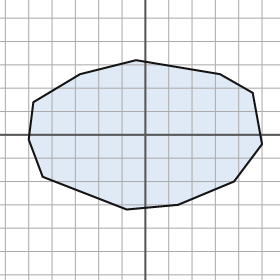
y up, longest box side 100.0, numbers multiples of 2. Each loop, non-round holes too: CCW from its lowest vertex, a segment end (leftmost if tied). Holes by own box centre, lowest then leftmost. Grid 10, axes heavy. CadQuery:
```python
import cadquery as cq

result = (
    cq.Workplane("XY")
    .moveTo(-8.0, -32.0)
    .lineTo(14.0, -30.0)
    .lineTo(38.0, -20.0)
    .lineTo(50.0, -4.0)
    .lineTo(46.0, 18.0)
    .lineTo(32.0, 26.0)
    .lineTo(-4.0, 32.0)
    .lineTo(-28.0, 26.0)
    .lineTo(-48.0, 14.0)
    .lineTo(-50.0, -2.0)
    .lineTo(-44.0, -18.0)
    .close()
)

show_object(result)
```